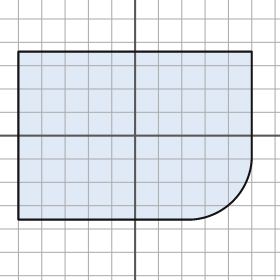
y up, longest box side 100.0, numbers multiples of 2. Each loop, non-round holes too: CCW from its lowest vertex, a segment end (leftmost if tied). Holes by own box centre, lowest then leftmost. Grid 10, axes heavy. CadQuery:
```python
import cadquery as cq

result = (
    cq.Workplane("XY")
    .moveTo(-50.0, -36.0)
    .lineTo(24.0, -36.0)
    .threePointArc((42.0, -28.0), (50.0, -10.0))
    .lineTo(50.0, 36.0)
    .lineTo(-50.0, 36.0)
    .close()
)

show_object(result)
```